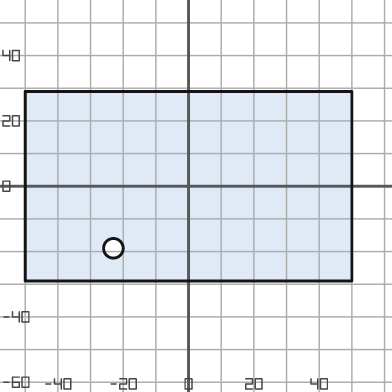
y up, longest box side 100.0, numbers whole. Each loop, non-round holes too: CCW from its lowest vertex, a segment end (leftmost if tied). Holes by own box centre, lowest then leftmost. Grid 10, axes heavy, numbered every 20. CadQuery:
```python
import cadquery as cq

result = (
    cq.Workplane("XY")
    .moveTo(-50.0, -29.0)
    .lineTo(50.0, -29.0)
    .lineTo(50.0, 29.0)
    .lineTo(-50.0, 29.0)
    .close()
    .moveTo(-23.0, -19.0)
    .circle(3.0)
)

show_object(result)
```